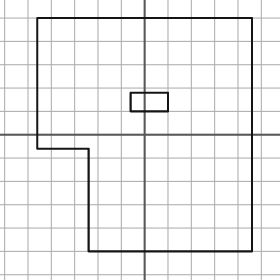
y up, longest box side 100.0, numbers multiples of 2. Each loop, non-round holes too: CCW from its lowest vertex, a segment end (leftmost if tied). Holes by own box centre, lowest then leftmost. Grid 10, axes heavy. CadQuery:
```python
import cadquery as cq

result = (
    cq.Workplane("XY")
    .moveTo(-24.0, -50.0)
    .lineTo(46.0, -50.0)
    .lineTo(46.0, 50.0)
    .lineTo(-46.0, 50.0)
    .lineTo(-46.0, -6.0)
    .lineTo(-24.0, -6.0)
    .close()
    .moveTo(-6.0, 10.0)
    .lineTo(10.0, 10.0)
    .lineTo(10.0, 18.0)
    .lineTo(-6.0, 18.0)
    .close()
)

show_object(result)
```